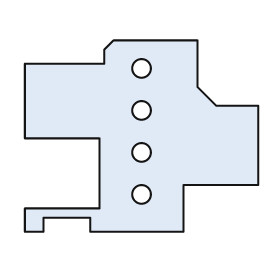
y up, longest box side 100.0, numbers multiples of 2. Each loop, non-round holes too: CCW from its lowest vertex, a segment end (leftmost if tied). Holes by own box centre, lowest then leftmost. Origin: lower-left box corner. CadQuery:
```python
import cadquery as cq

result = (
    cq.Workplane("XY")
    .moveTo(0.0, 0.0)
    .lineTo(8.0, 0.0)
    .lineTo(8.0, 6.0)
    .lineTo(28.0, 6.0)
    .lineTo(28.0, 0.0)
    .lineTo(68.0, 0.0)
    .lineTo(68.0, 20.0)
    .lineTo(100.0, 20.0)
    .lineTo(100.0, 54.0)
    .lineTo(82.0, 54.0)
    .lineTo(74.0, 62.0)
    .lineTo(74.0, 82.0)
    .lineTo(38.0, 82.0)
    .lineTo(34.0, 78.0)
    .lineTo(34.0, 72.0)
    .lineTo(0.0, 72.0)
    .lineTo(0.0, 40.0)
    .lineTo(32.0, 40.0)
    .lineTo(32.0, 10.0)
    .lineTo(0.0, 10.0)
    .close()
    .moveTo(50.0, 16.0)
    .circle(4.0)
    .moveTo(50.0, 34.0)
    .circle(4.0)
    .moveTo(50.0, 52.0)
    .circle(4.0)
    .moveTo(50.0, 70.0)
    .circle(4.0)
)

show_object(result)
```